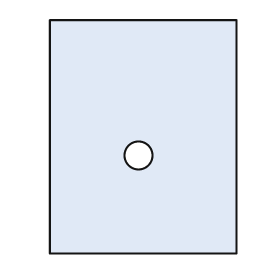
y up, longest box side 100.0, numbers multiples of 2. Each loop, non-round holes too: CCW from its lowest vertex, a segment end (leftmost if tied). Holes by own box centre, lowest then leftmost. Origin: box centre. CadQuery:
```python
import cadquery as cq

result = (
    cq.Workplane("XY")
    .moveTo(-40.0, -50.0)
    .lineTo(40.0, -50.0)
    .lineTo(40.0, 50.0)
    .lineTo(-40.0, 50.0)
    .close()
    .moveTo(-2.0, -8.0)
    .circle(6.0)
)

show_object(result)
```